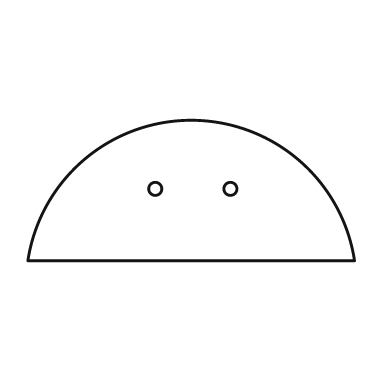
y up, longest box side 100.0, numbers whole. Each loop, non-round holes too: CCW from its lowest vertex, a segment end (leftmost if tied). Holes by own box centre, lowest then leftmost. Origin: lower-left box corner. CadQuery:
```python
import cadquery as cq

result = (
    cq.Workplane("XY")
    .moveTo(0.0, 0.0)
    .lineTo(100.0, 0.0)
    .threePointArc((50.0, 43.0), (0.0, 0.0))
    .close()
    .moveTo(39.0, 22.0)
    .circle(2.0)
    .moveTo(62.0, 22.0)
    .circle(2.0)
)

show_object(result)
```